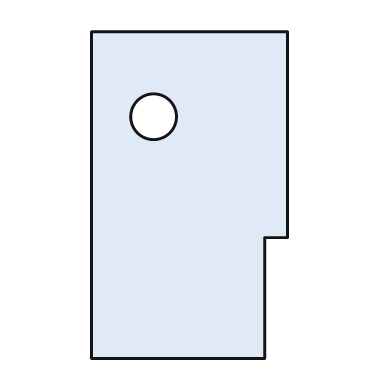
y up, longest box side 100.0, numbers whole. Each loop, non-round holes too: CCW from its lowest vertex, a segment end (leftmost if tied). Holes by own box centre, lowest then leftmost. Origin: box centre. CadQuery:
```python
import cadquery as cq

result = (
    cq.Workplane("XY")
    .moveTo(-30.0, -50.0)
    .lineTo(23.0, -50.0)
    .lineTo(23.0, -13.0)
    .lineTo(30.0, -13.0)
    .lineTo(30.0, 50.0)
    .lineTo(-30.0, 50.0)
    .close()
    .moveTo(-11.0, 24.0)
    .circle(7.0)
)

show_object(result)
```